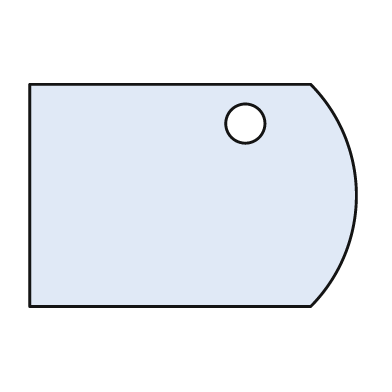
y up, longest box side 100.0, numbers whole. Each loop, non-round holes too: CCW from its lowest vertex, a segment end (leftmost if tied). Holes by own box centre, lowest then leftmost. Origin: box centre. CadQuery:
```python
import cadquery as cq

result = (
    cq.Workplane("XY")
    .moveTo(-50.0, -34.0)
    .lineTo(36.0, -34.0)
    .threePointArc((50.0, 0.0), (36.0, 34.0))
    .lineTo(-50.0, 34.0)
    .close()
    .moveTo(16.0, 22.0)
    .circle(6.0)
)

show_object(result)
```